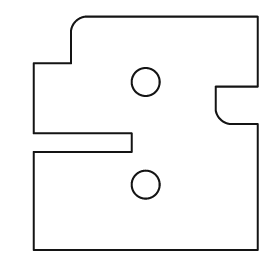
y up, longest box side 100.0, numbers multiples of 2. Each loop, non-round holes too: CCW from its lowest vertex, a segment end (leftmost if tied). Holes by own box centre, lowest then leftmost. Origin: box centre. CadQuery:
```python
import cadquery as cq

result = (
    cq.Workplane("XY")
    .moveTo(-48.0, -50.0)
    .lineTo(48.0, -50.0)
    .lineTo(48.0, 4.0)
    .lineTo(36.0, 4.0)
    .threePointArc((32.0, 6.0), (30.0, 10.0))
    .lineTo(30.0, 20.0)
    .lineTo(48.0, 20.0)
    .lineTo(48.0, 50.0)
    .lineTo(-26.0, 50.0)
    .threePointArc((-30.0, 48.0), (-32.0, 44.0))
    .lineTo(-32.0, 30.0)
    .lineTo(-48.0, 30.0)
    .lineTo(-48.0, 0.0)
    .lineTo(-6.0, 0.0)
    .lineTo(-6.0, -8.0)
    .lineTo(-48.0, -8.0)
    .close()
    .moveTo(0.0, -22.0)
    .circle(6.0)
    .moveTo(0.0, 22.0)
    .circle(6.0)
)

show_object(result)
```